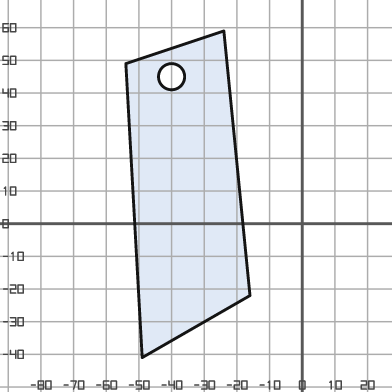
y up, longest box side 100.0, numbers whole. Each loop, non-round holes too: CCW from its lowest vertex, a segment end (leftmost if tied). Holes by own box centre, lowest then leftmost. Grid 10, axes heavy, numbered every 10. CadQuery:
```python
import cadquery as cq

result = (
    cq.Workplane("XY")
    .moveTo(-49.0, -41.0)
    .lineTo(-16.0, -22.0)
    .lineTo(-24.0, 59.0)
    .lineTo(-54.0, 49.0)
    .close()
    .moveTo(-40.0, 45.0)
    .circle(4.0)
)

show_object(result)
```